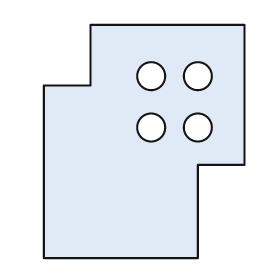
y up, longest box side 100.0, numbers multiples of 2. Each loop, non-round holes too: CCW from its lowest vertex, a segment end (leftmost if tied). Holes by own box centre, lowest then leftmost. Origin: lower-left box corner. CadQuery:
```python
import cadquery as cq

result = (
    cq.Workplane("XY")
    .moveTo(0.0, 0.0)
    .lineTo(66.0, 0.0)
    .lineTo(66.0, 40.0)
    .lineTo(86.0, 40.0)
    .lineTo(86.0, 100.0)
    .lineTo(20.0, 100.0)
    .lineTo(20.0, 74.0)
    .lineTo(0.0, 74.0)
    .close()
    .moveTo(46.0, 56.0)
    .circle(6.0)
    .moveTo(66.0, 56.0)
    .circle(6.0)
    .moveTo(46.0, 78.0)
    .circle(6.0)
    .moveTo(66.0, 78.0)
    .circle(6.0)
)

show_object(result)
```